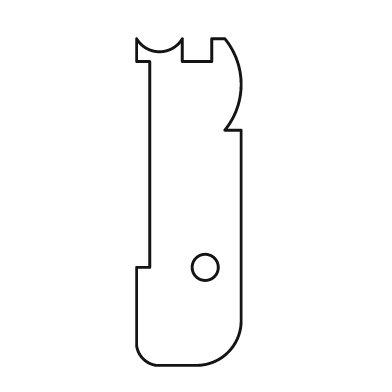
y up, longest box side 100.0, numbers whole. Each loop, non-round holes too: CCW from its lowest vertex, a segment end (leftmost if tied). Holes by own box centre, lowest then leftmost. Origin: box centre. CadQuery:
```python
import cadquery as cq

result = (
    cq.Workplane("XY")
    .moveTo(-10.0, -50.0)
    .lineTo(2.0, -50.0)
    .threePointArc((12.0, -46.0), (16.0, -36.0))
    .lineTo(16.0, 22.0)
    .lineTo(11.0, 22.0)
    .threePointArc((16.0, 36.0), (11.0, 50.0))
    .lineTo(7.0, 50.0)
    .lineTo(7.0, 43.0)
    .lineTo(-2.0, 43.0)
    .lineTo(-2.0, 50.0)
    .threePointArc((-9.0, 46.0), (-16.0, 50.0))
    .lineTo(-16.0, 43.0)
    .lineTo(-12.0, 43.0)
    .lineTo(-12.0, -20.0)
    .lineTo(-16.0, -20.0)
    .lineTo(-16.0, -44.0)
    .threePointArc((-14.0, -48.0), (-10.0, -50.0))
    .close()
    .moveTo(5.0, -20.0)
    .circle(4.0)
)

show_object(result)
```